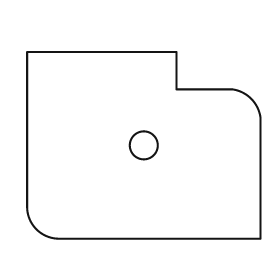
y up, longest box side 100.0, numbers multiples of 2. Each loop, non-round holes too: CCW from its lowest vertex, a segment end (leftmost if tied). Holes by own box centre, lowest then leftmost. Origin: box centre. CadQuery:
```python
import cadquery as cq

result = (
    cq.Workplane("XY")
    .moveTo(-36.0, -40.0)
    .lineTo(50.0, -40.0)
    .lineTo(50.0, 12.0)
    .threePointArc((46.0, 20.0), (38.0, 24.0))
    .lineTo(14.0, 24.0)
    .lineTo(14.0, 40.0)
    .lineTo(-50.0, 40.0)
    .lineTo(-50.0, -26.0)
    .threePointArc((-46.0, -36.0), (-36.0, -40.0))
    .close()
    .moveTo(0.0, 0.0)
    .circle(6.0)
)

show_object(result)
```